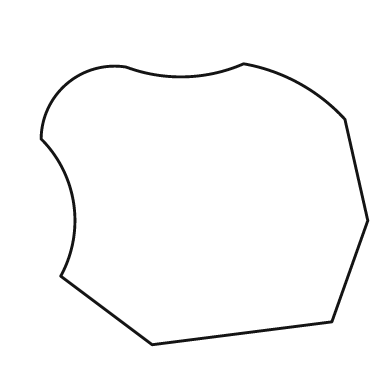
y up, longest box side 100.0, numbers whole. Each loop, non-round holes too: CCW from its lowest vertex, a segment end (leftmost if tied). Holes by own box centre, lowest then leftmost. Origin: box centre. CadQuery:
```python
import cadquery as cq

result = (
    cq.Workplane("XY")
    .moveTo(-16.0, -43.0)
    .lineTo(39.0, -36.0)
    .lineTo(50.0, -5.0)
    .lineTo(43.0, 26.0)
    .threePointArc((29.0, 37.0), (12.0, 43.0))
    .threePointArc((-6.0, 39.0), (-24.0, 42.0))
    .threePointArc((-42.0, 37.0), (-50.0, 20.0))
    .threePointArc((-40.0, 0.0), (-44.0, -22.0))
    .close()
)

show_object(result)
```